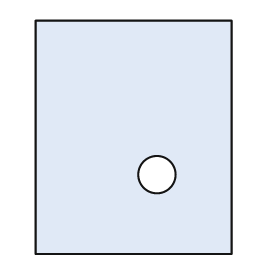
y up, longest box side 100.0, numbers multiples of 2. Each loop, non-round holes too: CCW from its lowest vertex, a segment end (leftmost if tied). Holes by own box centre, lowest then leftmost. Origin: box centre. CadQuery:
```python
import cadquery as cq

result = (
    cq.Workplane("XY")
    .moveTo(-42.0, -50.0)
    .lineTo(42.0, -50.0)
    .lineTo(42.0, 50.0)
    .lineTo(-42.0, 50.0)
    .close()
    .moveTo(10.0, -16.0)
    .circle(8.0)
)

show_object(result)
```